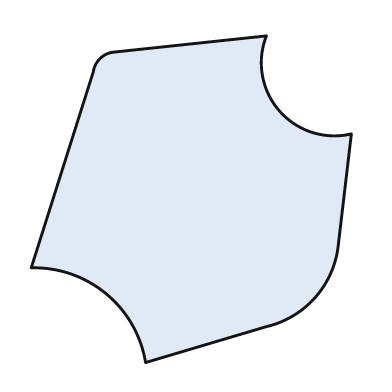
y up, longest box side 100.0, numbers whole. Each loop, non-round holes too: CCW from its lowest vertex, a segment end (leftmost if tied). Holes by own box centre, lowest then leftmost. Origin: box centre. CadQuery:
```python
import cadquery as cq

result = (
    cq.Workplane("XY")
    .moveTo(-14.0, -50.0)
    .lineTo(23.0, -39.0)
    .threePointArc((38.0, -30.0), (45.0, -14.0))
    .lineTo(49.0, 20.0)
    .threePointArc((27.0, 27.0), (23.0, 50.0))
    .lineTo(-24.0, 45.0)
    .threePointArc((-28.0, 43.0), (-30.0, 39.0))
    .lineTo(-49.0, -21.0)
    .threePointArc((-26.0, -29.0), (-14.0, -50.0))
    .close()
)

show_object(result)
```